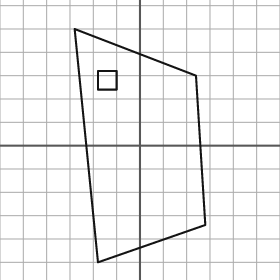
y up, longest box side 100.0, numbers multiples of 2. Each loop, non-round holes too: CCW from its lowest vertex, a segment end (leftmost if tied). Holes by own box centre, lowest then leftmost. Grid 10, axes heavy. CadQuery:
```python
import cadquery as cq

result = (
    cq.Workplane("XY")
    .moveTo(-18.0, -50.0)
    .lineTo(28.0, -34.0)
    .lineTo(24.0, 30.0)
    .lineTo(-28.0, 50.0)
    .close()
    .moveTo(-18.0, 24.0)
    .lineTo(-10.0, 24.0)
    .lineTo(-10.0, 32.0)
    .lineTo(-18.0, 32.0)
    .close()
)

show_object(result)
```